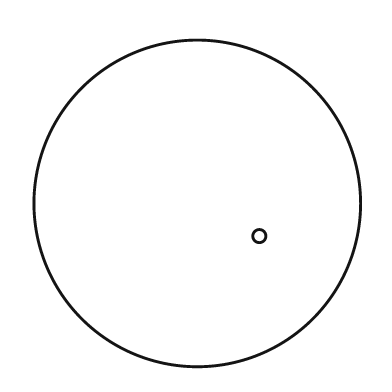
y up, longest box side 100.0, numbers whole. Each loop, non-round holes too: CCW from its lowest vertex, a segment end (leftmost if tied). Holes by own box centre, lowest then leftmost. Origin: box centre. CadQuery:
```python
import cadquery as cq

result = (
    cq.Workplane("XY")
    .moveTo(0.0, 0.0)
    .circle(50.0)
    .moveTo(19.0, -10.0)
    .circle(2.0)
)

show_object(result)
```